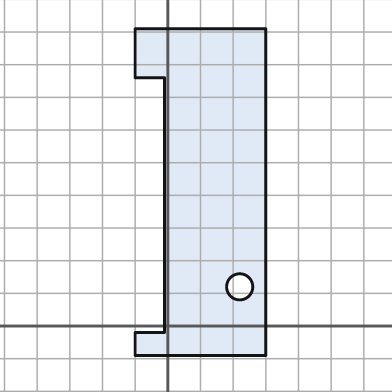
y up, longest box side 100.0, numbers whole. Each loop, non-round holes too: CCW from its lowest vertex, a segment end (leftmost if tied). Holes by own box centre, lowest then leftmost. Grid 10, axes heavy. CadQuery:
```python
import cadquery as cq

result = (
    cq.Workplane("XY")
    .moveTo(-10.0, -9.0)
    .lineTo(30.0, -9.0)
    .lineTo(30.0, 91.0)
    .lineTo(-10.0, 91.0)
    .lineTo(-10.0, 76.0)
    .lineTo(-1.0, 76.0)
    .lineTo(-1.0, -2.0)
    .lineTo(-10.0, -2.0)
    .close()
    .moveTo(22.0, 12.0)
    .circle(4.0)
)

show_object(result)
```